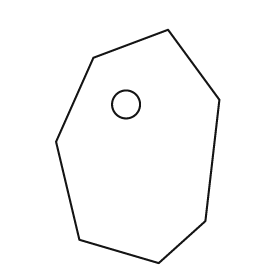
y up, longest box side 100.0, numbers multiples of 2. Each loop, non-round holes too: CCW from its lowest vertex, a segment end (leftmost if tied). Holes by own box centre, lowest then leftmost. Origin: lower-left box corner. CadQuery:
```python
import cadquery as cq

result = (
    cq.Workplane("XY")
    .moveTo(44.0, 0.0)
    .lineTo(64.0, 18.0)
    .lineTo(70.0, 70.0)
    .lineTo(48.0, 100.0)
    .lineTo(16.0, 88.0)
    .lineTo(0.0, 52.0)
    .lineTo(10.0, 10.0)
    .close()
    .moveTo(30.0, 68.0)
    .circle(6.0)
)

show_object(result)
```